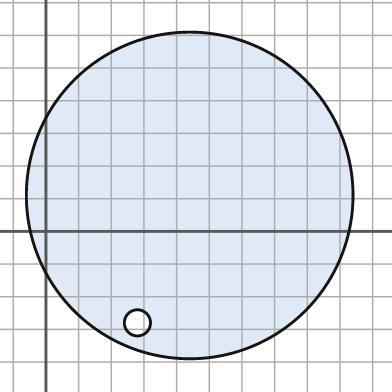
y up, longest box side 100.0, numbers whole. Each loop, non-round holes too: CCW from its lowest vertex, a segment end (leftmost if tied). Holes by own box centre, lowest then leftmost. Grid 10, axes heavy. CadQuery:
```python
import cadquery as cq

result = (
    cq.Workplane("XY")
    .moveTo(44.0, 11.0)
    .circle(50.0)
    .moveTo(28.0, -28.0)
    .circle(4.0)
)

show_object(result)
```